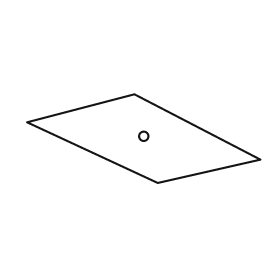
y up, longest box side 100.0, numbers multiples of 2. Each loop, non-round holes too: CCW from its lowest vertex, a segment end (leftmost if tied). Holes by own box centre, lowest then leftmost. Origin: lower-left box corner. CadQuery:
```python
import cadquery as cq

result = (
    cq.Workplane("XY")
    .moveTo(56.0, 0.0)
    .lineTo(100.0, 10.0)
    .lineTo(46.0, 38.0)
    .lineTo(0.0, 26.0)
    .close()
    .moveTo(50.0, 20.0)
    .circle(2.0)
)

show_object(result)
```